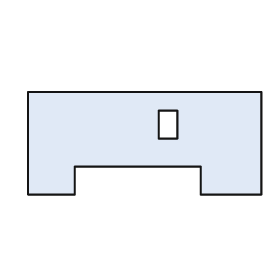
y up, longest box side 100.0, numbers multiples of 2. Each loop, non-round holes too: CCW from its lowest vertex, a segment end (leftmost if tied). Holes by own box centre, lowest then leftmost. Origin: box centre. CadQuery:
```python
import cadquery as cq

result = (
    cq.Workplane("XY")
    .moveTo(-50.0, -22.0)
    .lineTo(-30.0, -22.0)
    .lineTo(-30.0, -10.0)
    .lineTo(24.0, -10.0)
    .lineTo(24.0, -22.0)
    .lineTo(50.0, -22.0)
    .lineTo(50.0, 22.0)
    .lineTo(-50.0, 22.0)
    .close()
    .moveTo(6.0, 2.0)
    .lineTo(14.0, 2.0)
    .lineTo(14.0, 14.0)
    .lineTo(6.0, 14.0)
    .close()
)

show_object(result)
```